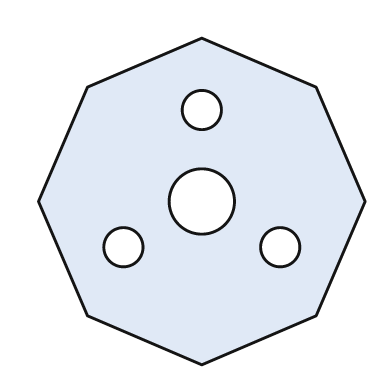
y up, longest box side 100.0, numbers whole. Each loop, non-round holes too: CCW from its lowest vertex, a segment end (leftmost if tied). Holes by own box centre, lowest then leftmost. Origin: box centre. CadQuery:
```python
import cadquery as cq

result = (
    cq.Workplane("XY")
    .moveTo(0.0, -50.0)
    .lineTo(35.0, -35.0)
    .lineTo(50.0, 0.0)
    .lineTo(35.0, 35.0)
    .lineTo(0.0, 50.0)
    .lineTo(-35.0, 35.0)
    .lineTo(-50.0, 0.0)
    .lineTo(-35.0, -35.0)
    .close()
    .moveTo(-24.0, -14.0)
    .circle(6.0)
    .moveTo(24.0, -14.0)
    .circle(6.0)
    .moveTo(0.0, 0.0)
    .circle(10.0)
    .moveTo(0.0, 28.0)
    .circle(6.0)
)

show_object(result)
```